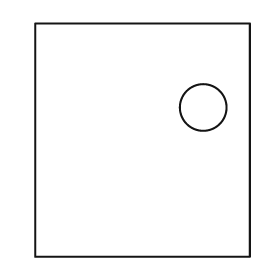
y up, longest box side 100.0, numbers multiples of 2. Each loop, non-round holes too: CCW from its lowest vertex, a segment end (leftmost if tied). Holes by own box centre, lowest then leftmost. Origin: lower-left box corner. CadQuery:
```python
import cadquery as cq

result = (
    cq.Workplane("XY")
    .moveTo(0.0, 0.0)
    .lineTo(92.0, 0.0)
    .lineTo(92.0, 100.0)
    .lineTo(0.0, 100.0)
    .close()
    .moveTo(72.0, 64.0)
    .circle(10.0)
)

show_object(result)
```